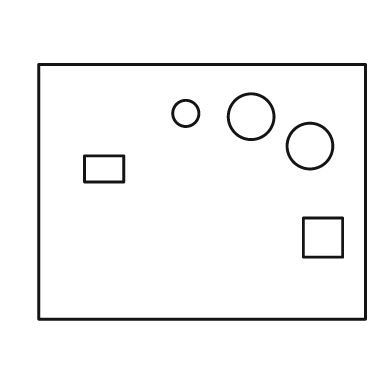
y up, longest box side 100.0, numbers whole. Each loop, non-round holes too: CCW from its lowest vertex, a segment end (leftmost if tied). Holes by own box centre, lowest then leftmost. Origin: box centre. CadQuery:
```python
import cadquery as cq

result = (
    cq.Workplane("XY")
    .moveTo(-50.0, -39.0)
    .lineTo(50.0, -39.0)
    .lineTo(50.0, 39.0)
    .lineTo(-50.0, 39.0)
    .close()
    .moveTo(31.0, -20.0)
    .lineTo(43.0, -20.0)
    .lineTo(43.0, -8.0)
    .lineTo(31.0, -8.0)
    .close()
    .moveTo(-36.0, 3.0)
    .lineTo(-24.0, 3.0)
    .lineTo(-24.0, 11.0)
    .lineTo(-36.0, 11.0)
    .close()
    .moveTo(33.0, 14.0)
    .circle(7.0)
    .moveTo(15.0, 23.0)
    .circle(7.0)
    .moveTo(-5.0, 24.0)
    .circle(4.0)
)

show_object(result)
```